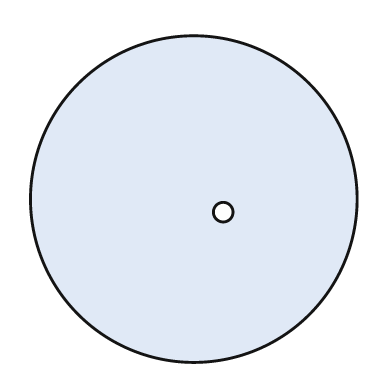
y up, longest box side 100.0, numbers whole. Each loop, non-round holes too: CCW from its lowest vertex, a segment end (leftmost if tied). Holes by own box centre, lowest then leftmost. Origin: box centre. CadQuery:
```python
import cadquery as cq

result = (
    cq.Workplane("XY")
    .moveTo(0.0, 0.0)
    .circle(50.0)
    .moveTo(9.0, -4.0)
    .circle(3.0)
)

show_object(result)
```